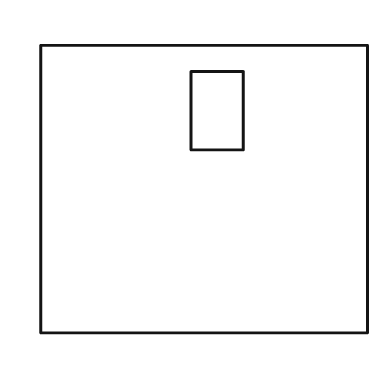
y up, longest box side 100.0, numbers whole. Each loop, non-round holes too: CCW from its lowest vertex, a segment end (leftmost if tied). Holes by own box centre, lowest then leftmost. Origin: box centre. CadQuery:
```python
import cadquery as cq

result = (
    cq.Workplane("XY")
    .moveTo(-50.0, -44.0)
    .lineTo(50.0, -44.0)
    .lineTo(50.0, 44.0)
    .lineTo(-50.0, 44.0)
    .close()
    .moveTo(-4.0, 12.0)
    .lineTo(12.0, 12.0)
    .lineTo(12.0, 36.0)
    .lineTo(-4.0, 36.0)
    .close()
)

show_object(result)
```